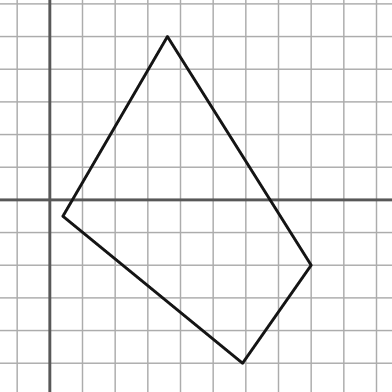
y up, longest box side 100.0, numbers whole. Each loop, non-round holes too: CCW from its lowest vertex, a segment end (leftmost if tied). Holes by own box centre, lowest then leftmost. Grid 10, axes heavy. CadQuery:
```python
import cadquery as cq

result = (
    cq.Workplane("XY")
    .moveTo(59.0, -50.0)
    .lineTo(80.0, -20.0)
    .lineTo(36.0, 50.0)
    .lineTo(4.0, -5.0)
    .close()
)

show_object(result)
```